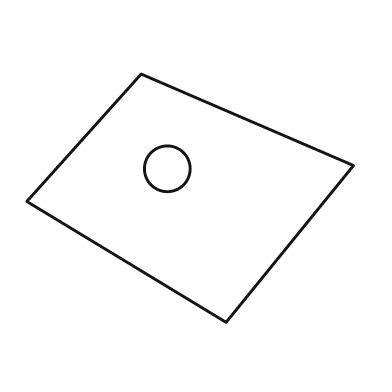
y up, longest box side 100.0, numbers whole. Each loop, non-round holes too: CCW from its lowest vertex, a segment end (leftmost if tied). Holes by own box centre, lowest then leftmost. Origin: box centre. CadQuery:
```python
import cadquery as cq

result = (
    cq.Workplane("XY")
    .moveTo(11.0, -38.0)
    .lineTo(50.0, 10.0)
    .lineTo(-15.0, 38.0)
    .lineTo(-50.0, -1.0)
    .close()
    .moveTo(-7.0, 9.0)
    .circle(7.0)
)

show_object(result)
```